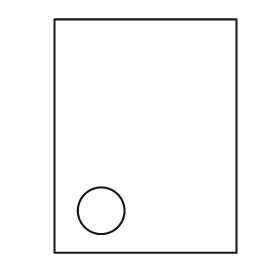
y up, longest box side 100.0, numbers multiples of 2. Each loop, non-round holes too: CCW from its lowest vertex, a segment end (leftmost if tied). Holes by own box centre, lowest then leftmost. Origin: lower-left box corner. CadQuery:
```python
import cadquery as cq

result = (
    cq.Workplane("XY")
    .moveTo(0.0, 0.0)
    .lineTo(78.0, 0.0)
    .lineTo(78.0, 100.0)
    .lineTo(0.0, 100.0)
    .close()
    .moveTo(20.0, 18.0)
    .circle(10.0)
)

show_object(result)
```